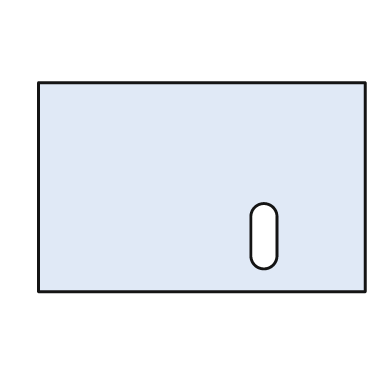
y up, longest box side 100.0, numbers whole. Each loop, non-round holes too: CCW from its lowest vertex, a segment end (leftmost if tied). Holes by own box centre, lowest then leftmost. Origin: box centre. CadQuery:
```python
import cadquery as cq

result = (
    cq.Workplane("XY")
    .moveTo(-50.0, -32.0)
    .lineTo(50.0, -32.0)
    .lineTo(50.0, 32.0)
    .lineTo(-50.0, 32.0)
    .close()
    .moveTo(15.0, -21.0)
    .threePointArc((19.0, -25.0), (23.0, -21.0))
    .lineTo(23.0, -9.0)
    .threePointArc((19.0, -5.0), (15.0, -9.0))
    .close()
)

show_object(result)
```